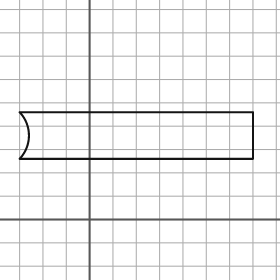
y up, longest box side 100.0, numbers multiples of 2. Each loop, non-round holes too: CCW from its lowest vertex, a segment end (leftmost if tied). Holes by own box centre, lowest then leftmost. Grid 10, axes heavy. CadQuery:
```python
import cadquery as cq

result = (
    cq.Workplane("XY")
    .moveTo(-30.0, 26.0)
    .lineTo(70.0, 26.0)
    .lineTo(70.0, 46.0)
    .lineTo(-30.0, 46.0)
    .threePointArc((-26.0, 36.0), (-30.0, 26.0))
    .close()
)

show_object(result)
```